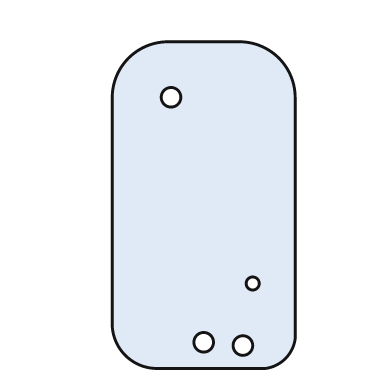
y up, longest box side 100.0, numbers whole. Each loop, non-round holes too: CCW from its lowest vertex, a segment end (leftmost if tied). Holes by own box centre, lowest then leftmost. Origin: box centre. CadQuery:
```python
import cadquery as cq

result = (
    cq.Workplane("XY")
    .moveTo(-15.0, -50.0)
    .lineTo(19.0, -50.0)
    .threePointArc((25.0, -47.0), (28.0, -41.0))
    .lineTo(28.0, 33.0)
    .threePointArc((23.0, 45.0), (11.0, 50.0))
    .lineTo(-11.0, 50.0)
    .threePointArc((-23.0, 45.0), (-28.0, 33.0))
    .lineTo(-28.0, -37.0)
    .threePointArc((-24.0, -46.0), (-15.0, -50.0))
    .close()
    .moveTo(12.0, -43.0)
    .circle(3.0)
    .moveTo(0.0, -42.0)
    .circle(3.0)
    .moveTo(15.0, -24.0)
    .circle(2.0)
    .moveTo(-10.0, 33.0)
    .circle(3.0)
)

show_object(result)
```